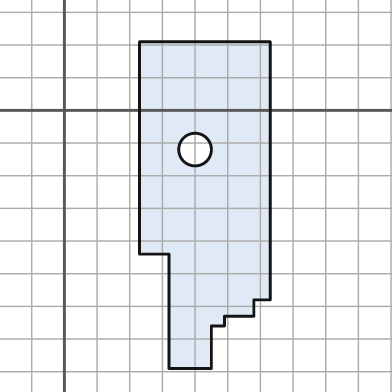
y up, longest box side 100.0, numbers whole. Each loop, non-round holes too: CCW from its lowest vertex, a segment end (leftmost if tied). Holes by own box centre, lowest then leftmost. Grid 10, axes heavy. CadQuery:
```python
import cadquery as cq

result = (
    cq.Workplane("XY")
    .moveTo(32.0, -79.0)
    .lineTo(45.0, -79.0)
    .lineTo(45.0, -66.0)
    .lineTo(49.0, -66.0)
    .lineTo(49.0, -63.0)
    .lineTo(58.0, -63.0)
    .lineTo(58.0, -58.0)
    .lineTo(63.0, -58.0)
    .lineTo(63.0, 21.0)
    .lineTo(23.0, 21.0)
    .lineTo(23.0, -44.0)
    .lineTo(32.0, -44.0)
    .close()
    .moveTo(40.0, -12.0)
    .circle(5.0)
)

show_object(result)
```